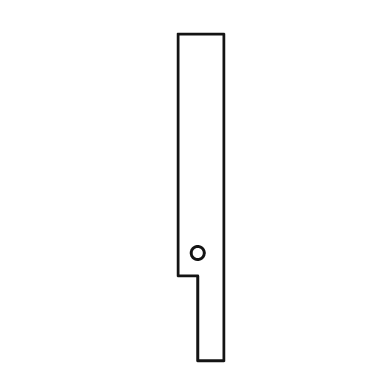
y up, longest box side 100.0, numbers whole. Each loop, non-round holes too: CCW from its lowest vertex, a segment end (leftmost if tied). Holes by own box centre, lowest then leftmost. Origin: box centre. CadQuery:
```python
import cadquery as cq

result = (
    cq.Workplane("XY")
    .moveTo(-1.0, -50.0)
    .lineTo(7.0, -50.0)
    .lineTo(7.0, 50.0)
    .lineTo(-7.0, 50.0)
    .lineTo(-7.0, -24.0)
    .lineTo(-1.0, -24.0)
    .close()
    .moveTo(-1.0, -17.0)
    .circle(2.0)
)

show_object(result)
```